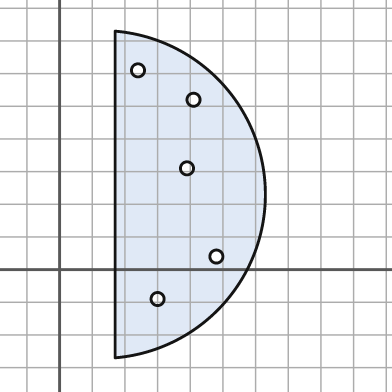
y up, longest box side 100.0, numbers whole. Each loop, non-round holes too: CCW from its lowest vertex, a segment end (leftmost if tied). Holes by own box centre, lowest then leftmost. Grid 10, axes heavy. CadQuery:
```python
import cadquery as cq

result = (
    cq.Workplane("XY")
    .moveTo(17.0, -27.0)
    .threePointArc((63.0, 23.0), (17.0, 73.0))
    .close()
    .moveTo(30.0, -9.0)
    .circle(2.0)
    .moveTo(48.0, 4.0)
    .circle(2.0)
    .moveTo(39.0, 31.0)
    .circle(2.0)
    .moveTo(41.0, 52.0)
    .circle(2.0)
    .moveTo(24.0, 61.0)
    .circle(2.0)
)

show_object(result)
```